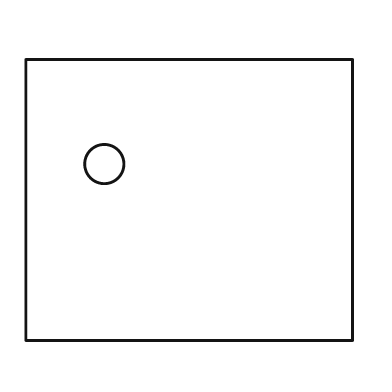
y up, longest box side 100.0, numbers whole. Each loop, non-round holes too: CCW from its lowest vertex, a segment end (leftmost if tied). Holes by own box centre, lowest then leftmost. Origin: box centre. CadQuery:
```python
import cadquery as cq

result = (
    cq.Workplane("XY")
    .moveTo(-50.0, -43.0)
    .lineTo(50.0, -43.0)
    .lineTo(50.0, 43.0)
    .lineTo(-50.0, 43.0)
    .close()
    .moveTo(-26.0, 11.0)
    .circle(6.0)
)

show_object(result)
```